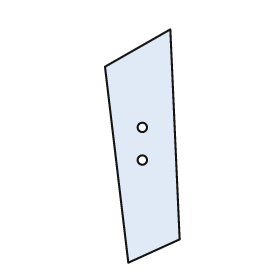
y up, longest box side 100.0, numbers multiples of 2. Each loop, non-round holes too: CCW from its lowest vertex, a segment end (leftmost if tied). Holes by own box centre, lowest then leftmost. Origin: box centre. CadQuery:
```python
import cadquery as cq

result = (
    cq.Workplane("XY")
    .moveTo(-6.0, -50.0)
    .lineTo(16.0, -40.0)
    .lineTo(12.0, 50.0)
    .lineTo(-16.0, 34.0)
    .close()
    .moveTo(0.0, -6.0)
    .circle(2.0)
    .moveTo(0.0, 8.0)
    .circle(2.0)
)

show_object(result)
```